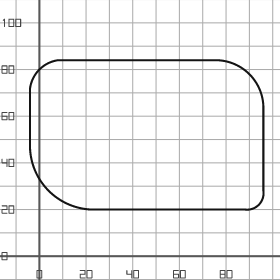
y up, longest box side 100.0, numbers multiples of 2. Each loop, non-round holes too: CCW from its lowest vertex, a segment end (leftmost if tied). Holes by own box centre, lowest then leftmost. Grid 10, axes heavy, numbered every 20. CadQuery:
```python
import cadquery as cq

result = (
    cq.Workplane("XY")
    .moveTo(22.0, 20.0)
    .lineTo(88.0, 20.0)
    .threePointArc((94.0, 22.0), (96.0, 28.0))
    .lineTo(96.0, 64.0)
    .threePointArc((90.0, 78.0), (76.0, 84.0))
    .lineTo(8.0, 84.0)
    .threePointArc((0.0, 80.0), (-4.0, 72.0))
    .lineTo(-4.0, 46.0)
    .threePointArc((4.0, 28.0), (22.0, 20.0))
    .close()
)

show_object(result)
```